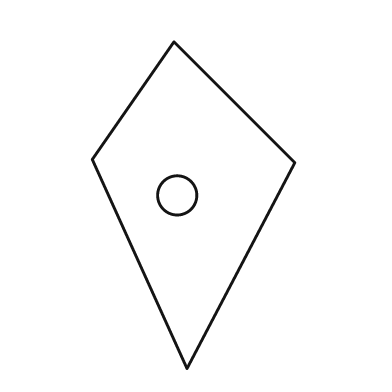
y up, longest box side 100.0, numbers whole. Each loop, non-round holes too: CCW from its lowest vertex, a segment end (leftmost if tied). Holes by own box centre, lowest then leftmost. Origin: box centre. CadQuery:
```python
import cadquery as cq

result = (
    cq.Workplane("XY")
    .moveTo(-2.0, -50.0)
    .lineTo(31.0, 13.0)
    .lineTo(-6.0, 50.0)
    .lineTo(-31.0, 14.0)
    .close()
    .moveTo(-5.0, 3.0)
    .circle(6.0)
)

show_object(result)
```